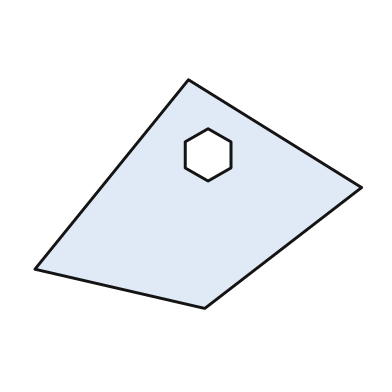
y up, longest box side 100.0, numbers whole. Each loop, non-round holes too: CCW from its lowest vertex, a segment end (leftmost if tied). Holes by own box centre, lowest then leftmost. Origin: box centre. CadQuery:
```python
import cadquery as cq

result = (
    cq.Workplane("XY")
    .moveTo(2.0, -35.0)
    .lineTo(50.0, 2.0)
    .lineTo(-3.0, 35.0)
    .lineTo(-50.0, -23.0)
    .close()
    .moveTo(3.0, 4.0)
    .lineTo(10.0, 8.0)
    .lineTo(10.0, 16.0)
    .lineTo(3.0, 20.0)
    .lineTo(-4.0, 16.0)
    .lineTo(-4.0, 8.0)
    .close()
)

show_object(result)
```